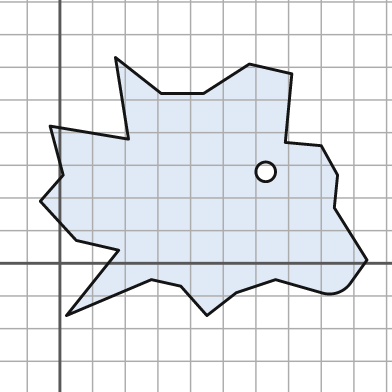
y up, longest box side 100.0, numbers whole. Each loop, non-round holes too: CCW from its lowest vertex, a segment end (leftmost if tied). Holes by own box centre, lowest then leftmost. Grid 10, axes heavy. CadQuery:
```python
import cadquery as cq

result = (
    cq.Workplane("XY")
    .moveTo(2.0, -16.0)
    .lineTo(28.0, -5.0)
    .lineTo(37.0, -7.0)
    .lineTo(45.0, -16.0)
    .lineTo(54.0, -9.0)
    .lineTo(66.0, -5.0)
    .lineTo(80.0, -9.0)
    .threePointArc((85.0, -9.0), (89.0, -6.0))
    .lineTo(94.0, 1.0)
    .lineTo(84.0, 17.0)
    .lineTo(85.0, 27.0)
    .lineTo(80.0, 36.0)
    .lineTo(69.0, 37.0)
    .lineTo(71.0, 58.0)
    .lineTo(58.0, 61.0)
    .lineTo(44.0, 52.0)
    .lineTo(31.0, 52.0)
    .lineTo(17.0, 63.0)
    .lineTo(21.0, 38.0)
    .lineTo(-3.0, 42.0)
    .lineTo(1.0, 27.0)
    .lineTo(-6.0, 19.0)
    .lineTo(5.0, 7.0)
    .lineTo(18.0, 4.0)
    .close()
    .moveTo(63.0, 28.0)
    .circle(3.0)
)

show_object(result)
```